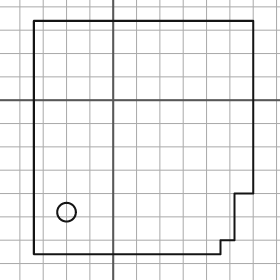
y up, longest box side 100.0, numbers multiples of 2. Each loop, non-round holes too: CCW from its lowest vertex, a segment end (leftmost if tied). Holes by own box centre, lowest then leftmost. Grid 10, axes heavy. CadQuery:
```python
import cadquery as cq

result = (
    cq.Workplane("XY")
    .moveTo(-34.0, -66.0)
    .lineTo(46.0, -66.0)
    .lineTo(46.0, -60.0)
    .lineTo(52.0, -60.0)
    .lineTo(52.0, -40.0)
    .lineTo(60.0, -40.0)
    .lineTo(60.0, 34.0)
    .lineTo(-34.0, 34.0)
    .close()
    .moveTo(-20.0, -48.0)
    .circle(4.0)
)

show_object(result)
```